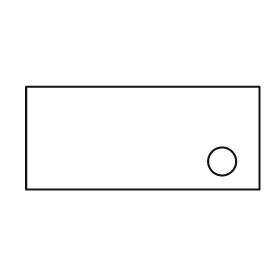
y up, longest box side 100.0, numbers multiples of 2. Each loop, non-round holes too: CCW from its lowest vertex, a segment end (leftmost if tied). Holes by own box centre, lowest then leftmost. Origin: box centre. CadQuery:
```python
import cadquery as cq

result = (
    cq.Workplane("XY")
    .moveTo(-50.0, -22.0)
    .lineTo(50.0, -22.0)
    .lineTo(50.0, 22.0)
    .lineTo(-50.0, 22.0)
    .close()
    .moveTo(34.0, -10.0)
    .circle(6.0)
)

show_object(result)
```